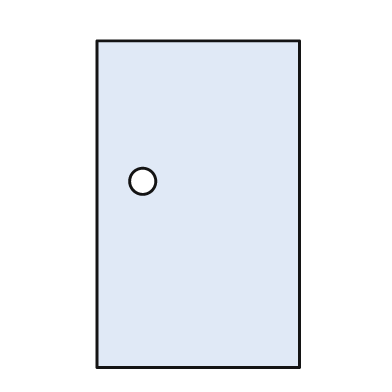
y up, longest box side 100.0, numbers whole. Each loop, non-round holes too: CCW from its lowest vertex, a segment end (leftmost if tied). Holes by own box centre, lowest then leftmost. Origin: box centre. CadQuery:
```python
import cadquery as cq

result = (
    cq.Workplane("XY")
    .moveTo(-31.0, -50.0)
    .lineTo(31.0, -50.0)
    .lineTo(31.0, 50.0)
    .lineTo(-31.0, 50.0)
    .close()
    .moveTo(-17.0, 7.0)
    .circle(4.0)
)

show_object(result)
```